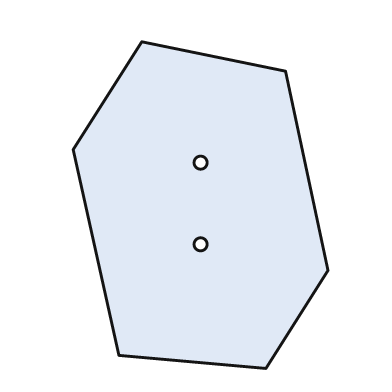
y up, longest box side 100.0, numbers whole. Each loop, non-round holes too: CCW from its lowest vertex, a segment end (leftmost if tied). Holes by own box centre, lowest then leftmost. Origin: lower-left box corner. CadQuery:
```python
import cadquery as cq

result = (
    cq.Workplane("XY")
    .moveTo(59.0, 0.0)
    .lineTo(78.0, 30.0)
    .lineTo(65.0, 91.0)
    .lineTo(21.0, 100.0)
    .lineTo(0.0, 67.0)
    .lineTo(14.0, 4.0)
    .close()
    .moveTo(39.0, 38.0)
    .circle(2.0)
    .moveTo(39.0, 63.0)
    .circle(2.0)
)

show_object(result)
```